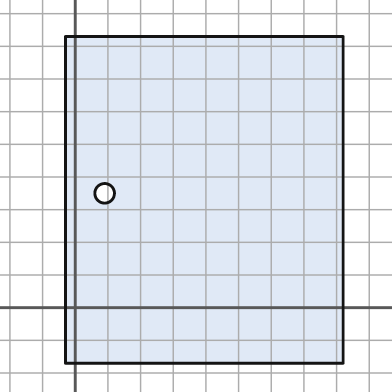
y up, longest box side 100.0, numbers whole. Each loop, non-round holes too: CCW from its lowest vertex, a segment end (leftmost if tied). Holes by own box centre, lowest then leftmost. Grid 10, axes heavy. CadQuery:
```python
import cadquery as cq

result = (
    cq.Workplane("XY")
    .moveTo(-3.0, -17.0)
    .lineTo(82.0, -17.0)
    .lineTo(82.0, 83.0)
    .lineTo(-3.0, 83.0)
    .close()
    .moveTo(9.0, 35.0)
    .circle(3.0)
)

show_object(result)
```